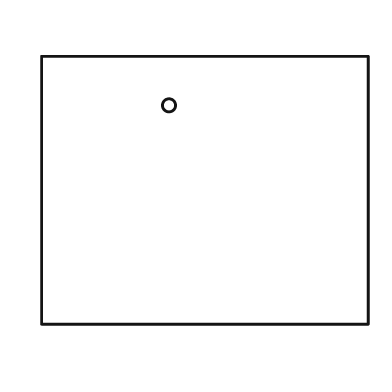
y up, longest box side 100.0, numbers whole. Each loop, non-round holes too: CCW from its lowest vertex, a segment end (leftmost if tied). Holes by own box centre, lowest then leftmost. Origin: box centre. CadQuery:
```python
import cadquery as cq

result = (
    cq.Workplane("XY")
    .moveTo(-50.0, -41.0)
    .lineTo(50.0, -41.0)
    .lineTo(50.0, 41.0)
    .lineTo(-50.0, 41.0)
    .close()
    .moveTo(-11.0, 26.0)
    .circle(2.0)
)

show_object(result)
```